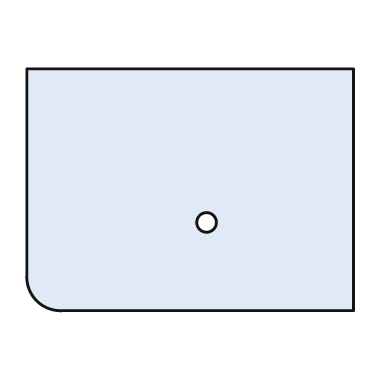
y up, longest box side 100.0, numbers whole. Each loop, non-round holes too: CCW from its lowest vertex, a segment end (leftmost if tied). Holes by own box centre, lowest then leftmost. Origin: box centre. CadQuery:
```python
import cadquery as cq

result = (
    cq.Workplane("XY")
    .moveTo(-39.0, -37.0)
    .lineTo(50.0, -37.0)
    .lineTo(50.0, 37.0)
    .lineTo(-50.0, 37.0)
    .lineTo(-50.0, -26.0)
    .threePointArc((-47.0, -34.0), (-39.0, -37.0))
    .close()
    .moveTo(5.0, -10.0)
    .circle(3.0)
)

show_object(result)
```